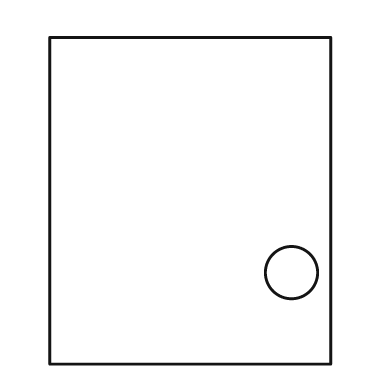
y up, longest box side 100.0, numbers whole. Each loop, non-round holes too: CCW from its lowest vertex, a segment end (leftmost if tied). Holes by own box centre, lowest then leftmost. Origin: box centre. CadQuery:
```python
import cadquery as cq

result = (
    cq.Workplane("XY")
    .moveTo(-43.0, -50.0)
    .lineTo(43.0, -50.0)
    .lineTo(43.0, 50.0)
    .lineTo(-43.0, 50.0)
    .close()
    .moveTo(31.0, -22.0)
    .circle(8.0)
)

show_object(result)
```